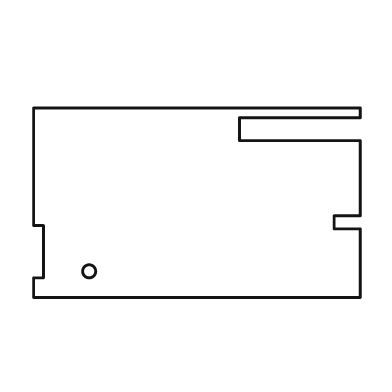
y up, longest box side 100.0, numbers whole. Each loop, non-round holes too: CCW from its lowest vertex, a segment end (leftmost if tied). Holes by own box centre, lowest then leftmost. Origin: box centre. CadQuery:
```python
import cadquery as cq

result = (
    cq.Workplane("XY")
    .moveTo(-50.0, -29.0)
    .lineTo(50.0, -29.0)
    .lineTo(50.0, -8.0)
    .lineTo(42.0, -8.0)
    .lineTo(42.0, -4.0)
    .lineTo(50.0, -4.0)
    .lineTo(50.0, 19.0)
    .lineTo(13.0, 19.0)
    .lineTo(13.0, 26.0)
    .lineTo(50.0, 26.0)
    .lineTo(50.0, 29.0)
    .lineTo(-50.0, 29.0)
    .lineTo(-50.0, -7.0)
    .lineTo(-47.0, -7.0)
    .lineTo(-47.0, -23.0)
    .lineTo(-50.0, -23.0)
    .close()
    .moveTo(-33.0, -21.0)
    .circle(2.0)
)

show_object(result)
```